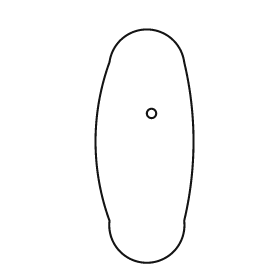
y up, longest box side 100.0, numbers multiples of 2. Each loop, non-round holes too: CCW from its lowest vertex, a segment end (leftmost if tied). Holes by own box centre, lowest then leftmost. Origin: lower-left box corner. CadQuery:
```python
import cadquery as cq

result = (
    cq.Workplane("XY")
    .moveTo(6.0, 18.0)
    .threePointArc((22.0, 0.0), (38.0, 18.0))
    .threePointArc((42.0, 52.0), (38.0, 86.0))
    .threePointArc((22.0, 100.0), (6.0, 86.0))
    .threePointArc((0.0, 52.0), (6.0, 18.0))
    .close()
    .moveTo(24.0, 64.0)
    .circle(2.0)
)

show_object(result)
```